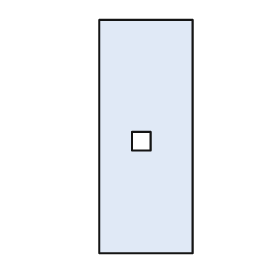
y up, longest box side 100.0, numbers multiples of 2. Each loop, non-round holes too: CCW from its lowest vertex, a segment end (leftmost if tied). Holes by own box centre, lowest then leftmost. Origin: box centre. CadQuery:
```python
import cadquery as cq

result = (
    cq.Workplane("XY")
    .moveTo(-20.0, -50.0)
    .lineTo(20.0, -50.0)
    .lineTo(20.0, 50.0)
    .lineTo(-20.0, 50.0)
    .close()
    .moveTo(-6.0, -6.0)
    .lineTo(2.0, -6.0)
    .lineTo(2.0, 2.0)
    .lineTo(-6.0, 2.0)
    .close()
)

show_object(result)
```